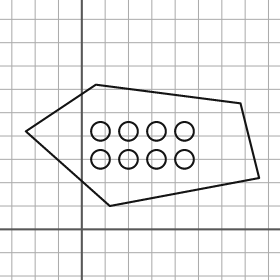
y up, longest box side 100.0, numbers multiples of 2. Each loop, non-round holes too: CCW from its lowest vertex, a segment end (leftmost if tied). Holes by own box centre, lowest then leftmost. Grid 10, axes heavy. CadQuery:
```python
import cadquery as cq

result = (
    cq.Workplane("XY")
    .moveTo(12.0, 10.0)
    .lineTo(76.0, 22.0)
    .lineTo(68.0, 54.0)
    .lineTo(6.0, 62.0)
    .lineTo(-24.0, 42.0)
    .close()
    .moveTo(8.0, 30.0)
    .circle(4.0)
    .moveTo(20.0, 30.0)
    .circle(4.0)
    .moveTo(32.0, 30.0)
    .circle(4.0)
    .moveTo(44.0, 30.0)
    .circle(4.0)
    .moveTo(8.0, 42.0)
    .circle(4.0)
    .moveTo(20.0, 42.0)
    .circle(4.0)
    .moveTo(32.0, 42.0)
    .circle(4.0)
    .moveTo(44.0, 42.0)
    .circle(4.0)
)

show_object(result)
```